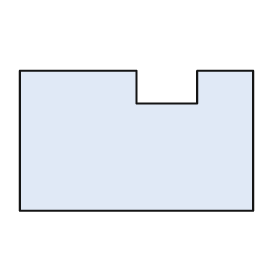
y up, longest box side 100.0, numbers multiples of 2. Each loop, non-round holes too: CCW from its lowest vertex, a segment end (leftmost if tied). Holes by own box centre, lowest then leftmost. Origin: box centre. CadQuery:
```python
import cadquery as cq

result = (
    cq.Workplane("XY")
    .moveTo(-50.0, -30.0)
    .lineTo(50.0, -30.0)
    .lineTo(50.0, 30.0)
    .lineTo(26.0, 30.0)
    .lineTo(26.0, 16.0)
    .lineTo(0.0, 16.0)
    .lineTo(0.0, 30.0)
    .lineTo(-50.0, 30.0)
    .close()
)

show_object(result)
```